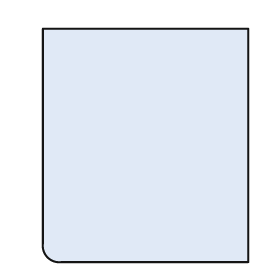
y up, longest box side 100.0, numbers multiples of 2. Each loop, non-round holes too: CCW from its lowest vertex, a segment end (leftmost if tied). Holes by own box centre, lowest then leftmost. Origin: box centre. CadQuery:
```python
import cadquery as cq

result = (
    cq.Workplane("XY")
    .moveTo(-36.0, -50.0)
    .lineTo(44.0, -50.0)
    .lineTo(44.0, 50.0)
    .lineTo(-44.0, 50.0)
    .lineTo(-44.0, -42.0)
    .threePointArc((-42.0, -48.0), (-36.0, -50.0))
    .close()
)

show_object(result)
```